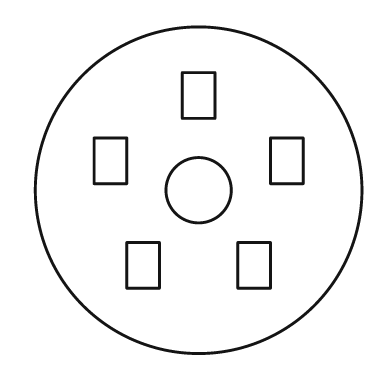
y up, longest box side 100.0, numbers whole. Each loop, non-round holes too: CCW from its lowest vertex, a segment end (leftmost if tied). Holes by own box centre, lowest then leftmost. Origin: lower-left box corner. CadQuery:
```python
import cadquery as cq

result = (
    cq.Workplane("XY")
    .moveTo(50.0, 50.0)
    .circle(50.0)
    .moveTo(28.0, 20.0)
    .lineTo(38.0, 20.0)
    .lineTo(38.0, 34.0)
    .lineTo(28.0, 34.0)
    .close()
    .moveTo(62.0, 20.0)
    .lineTo(72.0, 20.0)
    .lineTo(72.0, 34.0)
    .lineTo(62.0, 34.0)
    .close()
    .moveTo(50.0, 50.0)
    .circle(10.0)
    .moveTo(18.0, 52.0)
    .lineTo(28.0, 52.0)
    .lineTo(28.0, 66.0)
    .lineTo(18.0, 66.0)
    .close()
    .moveTo(72.0, 52.0)
    .lineTo(82.0, 52.0)
    .lineTo(82.0, 66.0)
    .lineTo(72.0, 66.0)
    .close()
    .moveTo(45.0, 72.0)
    .lineTo(55.0, 72.0)
    .lineTo(55.0, 86.0)
    .lineTo(45.0, 86.0)
    .close()
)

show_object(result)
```